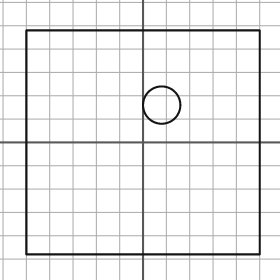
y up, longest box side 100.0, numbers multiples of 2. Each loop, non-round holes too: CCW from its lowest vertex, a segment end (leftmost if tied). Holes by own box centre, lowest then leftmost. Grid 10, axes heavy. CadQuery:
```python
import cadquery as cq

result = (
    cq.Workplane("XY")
    .moveTo(-50.0, -48.0)
    .lineTo(50.0, -48.0)
    .lineTo(50.0, 48.0)
    .lineTo(-50.0, 48.0)
    .close()
    .moveTo(8.0, 16.0)
    .circle(8.0)
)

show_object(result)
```